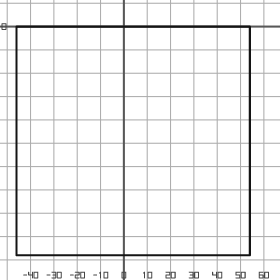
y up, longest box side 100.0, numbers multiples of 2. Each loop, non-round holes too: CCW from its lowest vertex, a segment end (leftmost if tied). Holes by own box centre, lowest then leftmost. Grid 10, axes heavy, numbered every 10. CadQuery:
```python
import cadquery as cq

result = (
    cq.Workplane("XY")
    .moveTo(-46.0, -98.0)
    .lineTo(54.0, -98.0)
    .lineTo(54.0, 0.0)
    .lineTo(-46.0, 0.0)
    .close()
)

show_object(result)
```